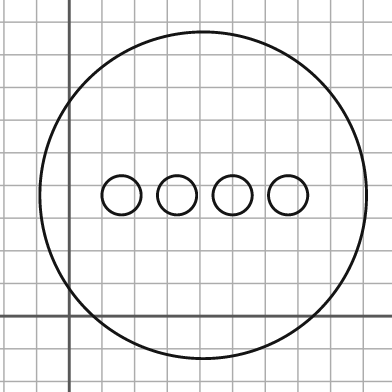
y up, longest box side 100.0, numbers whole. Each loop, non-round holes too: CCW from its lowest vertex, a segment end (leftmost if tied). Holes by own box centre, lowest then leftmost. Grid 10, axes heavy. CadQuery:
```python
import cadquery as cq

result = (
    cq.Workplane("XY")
    .moveTo(41.0, 37.0)
    .circle(50.0)
    .moveTo(16.0, 37.0)
    .circle(6.0)
    .moveTo(33.0, 37.0)
    .circle(6.0)
    .moveTo(50.0, 37.0)
    .circle(6.0)
    .moveTo(67.0, 37.0)
    .circle(6.0)
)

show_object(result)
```